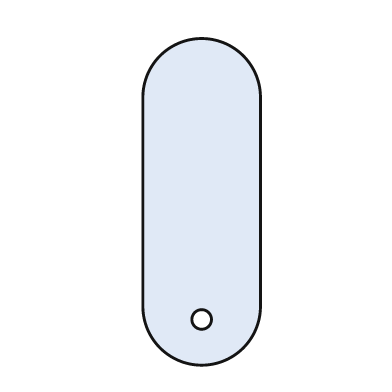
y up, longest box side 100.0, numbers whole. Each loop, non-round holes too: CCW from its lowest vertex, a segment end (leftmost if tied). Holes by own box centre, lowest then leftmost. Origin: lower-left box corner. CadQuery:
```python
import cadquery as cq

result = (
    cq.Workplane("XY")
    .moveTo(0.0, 18.0)
    .threePointArc((18.0, 0.0), (36.0, 18.0))
    .lineTo(36.0, 82.0)
    .threePointArc((18.0, 100.0), (0.0, 82.0))
    .close()
    .moveTo(18.0, 14.0)
    .circle(3.0)
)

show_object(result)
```